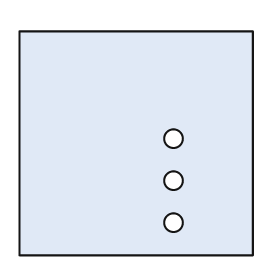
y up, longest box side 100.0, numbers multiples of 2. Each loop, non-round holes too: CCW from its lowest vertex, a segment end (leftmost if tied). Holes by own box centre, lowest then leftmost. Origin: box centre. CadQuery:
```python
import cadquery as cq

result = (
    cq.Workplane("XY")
    .moveTo(-50.0, -48.0)
    .lineTo(50.0, -48.0)
    .lineTo(50.0, 48.0)
    .lineTo(-50.0, 48.0)
    .close()
    .moveTo(16.0, -34.0)
    .circle(4.0)
    .moveTo(16.0, -16.0)
    .circle(4.0)
    .moveTo(16.0, 2.0)
    .circle(4.0)
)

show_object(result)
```